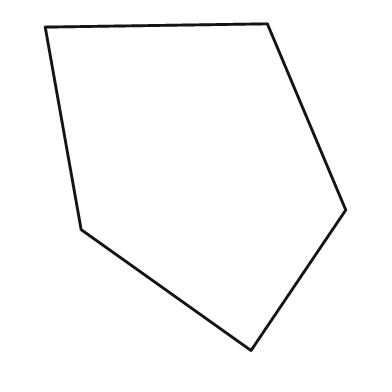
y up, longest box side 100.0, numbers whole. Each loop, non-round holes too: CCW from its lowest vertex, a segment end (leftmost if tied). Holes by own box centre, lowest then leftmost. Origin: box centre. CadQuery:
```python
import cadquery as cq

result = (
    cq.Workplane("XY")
    .moveTo(17.0, -50.0)
    .lineTo(46.0, -7.0)
    .lineTo(22.0, 50.0)
    .lineTo(-46.0, 49.0)
    .lineTo(-35.0, -13.0)
    .close()
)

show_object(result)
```